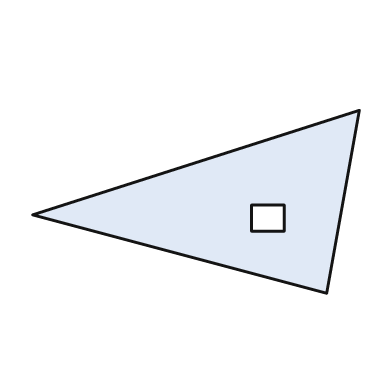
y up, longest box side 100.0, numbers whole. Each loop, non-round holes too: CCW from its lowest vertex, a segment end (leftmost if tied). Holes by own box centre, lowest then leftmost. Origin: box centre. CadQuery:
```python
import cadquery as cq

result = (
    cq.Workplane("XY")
    .moveTo(40.0, -28.0)
    .lineTo(50.0, 28.0)
    .lineTo(-50.0, -4.0)
    .close()
    .moveTo(17.0, -9.0)
    .lineTo(27.0, -9.0)
    .lineTo(27.0, -1.0)
    .lineTo(17.0, -1.0)
    .close()
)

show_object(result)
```